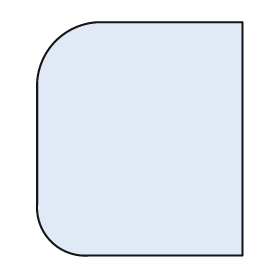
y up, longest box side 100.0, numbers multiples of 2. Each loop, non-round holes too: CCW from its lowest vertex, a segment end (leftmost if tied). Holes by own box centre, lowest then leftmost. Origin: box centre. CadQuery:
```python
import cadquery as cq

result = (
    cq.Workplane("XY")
    .moveTo(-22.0, -50.0)
    .lineTo(44.0, -50.0)
    .lineTo(44.0, 50.0)
    .lineTo(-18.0, 50.0)
    .threePointArc((-36.0, 42.0), (-44.0, 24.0))
    .lineTo(-44.0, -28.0)
    .threePointArc((-38.0, -44.0), (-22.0, -50.0))
    .close()
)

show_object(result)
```